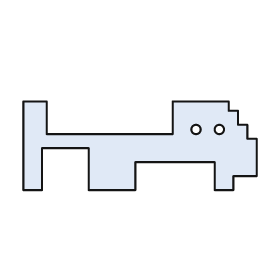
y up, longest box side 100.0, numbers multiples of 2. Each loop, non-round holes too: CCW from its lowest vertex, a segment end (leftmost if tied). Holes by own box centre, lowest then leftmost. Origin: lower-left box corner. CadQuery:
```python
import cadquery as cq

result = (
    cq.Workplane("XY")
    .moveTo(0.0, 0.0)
    .lineTo(8.0, 0.0)
    .lineTo(8.0, 18.0)
    .lineTo(28.0, 18.0)
    .lineTo(28.0, 0.0)
    .lineTo(48.0, 0.0)
    .lineTo(48.0, 12.0)
    .lineTo(82.0, 12.0)
    .lineTo(82.0, 0.0)
    .lineTo(90.0, 0.0)
    .lineTo(90.0, 6.0)
    .lineTo(100.0, 6.0)
    .lineTo(100.0, 22.0)
    .lineTo(96.0, 22.0)
    .lineTo(96.0, 28.0)
    .lineTo(92.0, 28.0)
    .lineTo(92.0, 34.0)
    .lineTo(88.0, 34.0)
    .lineTo(88.0, 38.0)
    .lineTo(64.0, 38.0)
    .lineTo(64.0, 24.0)
    .lineTo(10.0, 24.0)
    .lineTo(10.0, 38.0)
    .lineTo(0.0, 38.0)
    .close()
    .moveTo(74.0, 26.0)
    .circle(2.0)
    .moveTo(84.0, 26.0)
    .circle(2.0)
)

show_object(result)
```